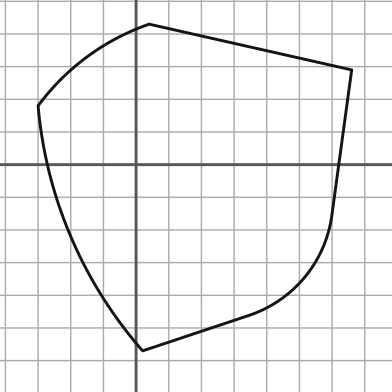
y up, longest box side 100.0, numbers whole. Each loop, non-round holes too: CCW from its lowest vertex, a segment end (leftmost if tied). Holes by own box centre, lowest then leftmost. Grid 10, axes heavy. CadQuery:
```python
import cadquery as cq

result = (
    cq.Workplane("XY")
    .moveTo(2.0, -57.0)
    .lineTo(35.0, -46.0)
    .threePointArc((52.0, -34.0), (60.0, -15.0))
    .lineTo(66.0, 29.0)
    .lineTo(4.0, 43.0)
    .threePointArc((-15.0, 33.0), (-30.0, 18.0))
    .threePointArc((-20.0, -22.0), (2.0, -57.0))
    .close()
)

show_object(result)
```